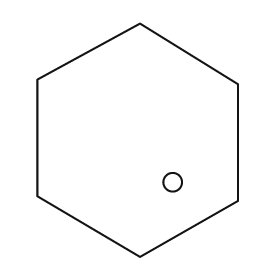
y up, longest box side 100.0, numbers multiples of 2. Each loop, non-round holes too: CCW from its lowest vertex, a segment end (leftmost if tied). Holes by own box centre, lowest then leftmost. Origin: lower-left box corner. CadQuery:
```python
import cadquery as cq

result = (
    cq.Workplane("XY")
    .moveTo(44.0, 0.0)
    .lineTo(86.0, 24.0)
    .lineTo(86.0, 74.0)
    .lineTo(44.0, 100.0)
    .lineTo(0.0, 76.0)
    .lineTo(0.0, 26.0)
    .close()
    .moveTo(58.0, 32.0)
    .circle(4.0)
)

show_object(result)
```